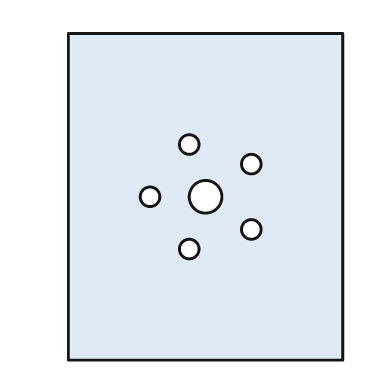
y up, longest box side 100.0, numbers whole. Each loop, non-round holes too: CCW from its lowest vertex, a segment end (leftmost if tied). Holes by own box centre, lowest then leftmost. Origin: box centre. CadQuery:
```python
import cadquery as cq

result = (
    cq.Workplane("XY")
    .moveTo(-42.0, -50.0)
    .lineTo(42.0, -50.0)
    .lineTo(42.0, 50.0)
    .lineTo(-42.0, 50.0)
    .close()
    .moveTo(-5.0, -16.0)
    .circle(3.0)
    .moveTo(14.0, -10.0)
    .circle(3.0)
    .moveTo(-17.0, 0.0)
    .circle(3.0)
    .moveTo(0.0, 0.0)
    .circle(5.0)
    .moveTo(14.0, 10.0)
    .circle(3.0)
    .moveTo(-5.0, 16.0)
    .circle(3.0)
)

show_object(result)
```